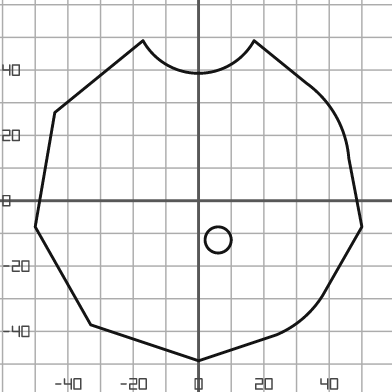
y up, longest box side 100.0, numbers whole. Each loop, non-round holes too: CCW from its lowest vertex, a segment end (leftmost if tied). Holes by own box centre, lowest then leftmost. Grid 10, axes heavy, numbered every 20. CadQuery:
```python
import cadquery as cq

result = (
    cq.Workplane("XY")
    .moveTo(0.0, -49.0)
    .lineTo(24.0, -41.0)
    .threePointArc((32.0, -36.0), (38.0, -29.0))
    .lineTo(50.0, -8.0)
    .lineTo(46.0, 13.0)
    .threePointArc((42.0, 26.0), (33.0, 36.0))
    .lineTo(17.0, 49.0)
    .threePointArc((0.0, 39.0), (-17.0, 49.0))
    .lineTo(-44.0, 27.0)
    .lineTo(-50.0, -8.0)
    .lineTo(-33.0, -38.0)
    .close()
    .moveTo(6.0, -12.0)
    .circle(4.0)
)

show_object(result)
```